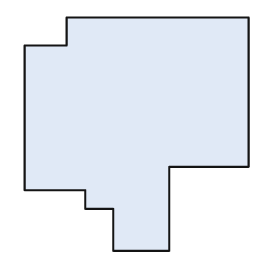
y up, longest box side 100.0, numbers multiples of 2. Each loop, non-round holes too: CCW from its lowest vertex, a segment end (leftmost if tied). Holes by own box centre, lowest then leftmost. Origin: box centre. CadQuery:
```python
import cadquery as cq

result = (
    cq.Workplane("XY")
    .moveTo(-10.0, -50.0)
    .lineTo(14.0, -50.0)
    .lineTo(14.0, -14.0)
    .lineTo(48.0, -14.0)
    .lineTo(48.0, 50.0)
    .lineTo(-30.0, 50.0)
    .lineTo(-30.0, 38.0)
    .lineTo(-48.0, 38.0)
    .lineTo(-48.0, -24.0)
    .lineTo(-22.0, -24.0)
    .lineTo(-22.0, -32.0)
    .lineTo(-10.0, -32.0)
    .close()
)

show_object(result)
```